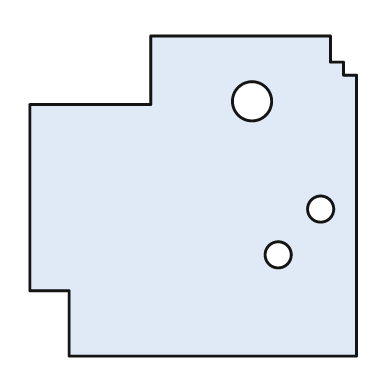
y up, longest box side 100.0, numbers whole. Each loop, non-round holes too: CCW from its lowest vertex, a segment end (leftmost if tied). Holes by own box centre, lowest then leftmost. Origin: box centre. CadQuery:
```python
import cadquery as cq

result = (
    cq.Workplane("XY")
    .moveTo(-38.0, -49.0)
    .lineTo(50.0, -49.0)
    .lineTo(50.0, 37.0)
    .lineTo(46.0, 37.0)
    .lineTo(46.0, 41.0)
    .lineTo(42.0, 41.0)
    .lineTo(42.0, 49.0)
    .lineTo(-13.0, 49.0)
    .lineTo(-13.0, 28.0)
    .lineTo(-50.0, 28.0)
    .lineTo(-50.0, -29.0)
    .lineTo(-38.0, -29.0)
    .close()
    .moveTo(26.0, -18.0)
    .circle(4.0)
    .moveTo(39.0, -4.0)
    .circle(4.0)
    .moveTo(18.0, 29.0)
    .circle(6.0)
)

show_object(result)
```